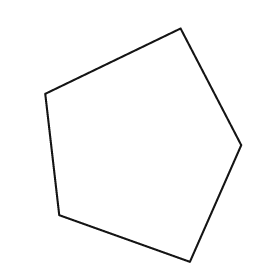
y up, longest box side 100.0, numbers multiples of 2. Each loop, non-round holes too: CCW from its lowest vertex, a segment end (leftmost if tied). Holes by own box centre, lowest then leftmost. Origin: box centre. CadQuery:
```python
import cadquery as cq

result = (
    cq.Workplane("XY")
    .moveTo(20.0, -50.0)
    .lineTo(42.0, 0.0)
    .lineTo(16.0, 50.0)
    .lineTo(-42.0, 22.0)
    .lineTo(-36.0, -30.0)
    .close()
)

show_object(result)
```